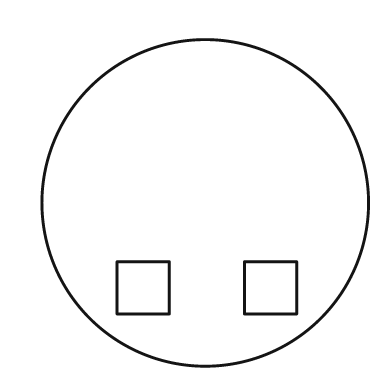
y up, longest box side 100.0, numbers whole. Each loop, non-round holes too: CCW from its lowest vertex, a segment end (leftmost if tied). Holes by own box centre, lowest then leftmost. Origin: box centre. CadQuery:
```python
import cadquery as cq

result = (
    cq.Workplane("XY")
    .moveTo(0.0, 0.0)
    .circle(50.0)
    .moveTo(-27.0, -34.0)
    .lineTo(-11.0, -34.0)
    .lineTo(-11.0, -18.0)
    .lineTo(-27.0, -18.0)
    .close()
    .moveTo(12.0, -34.0)
    .lineTo(28.0, -34.0)
    .lineTo(28.0, -18.0)
    .lineTo(12.0, -18.0)
    .close()
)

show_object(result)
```